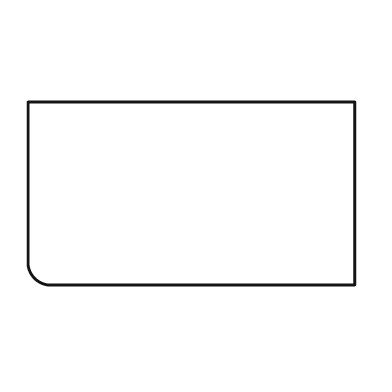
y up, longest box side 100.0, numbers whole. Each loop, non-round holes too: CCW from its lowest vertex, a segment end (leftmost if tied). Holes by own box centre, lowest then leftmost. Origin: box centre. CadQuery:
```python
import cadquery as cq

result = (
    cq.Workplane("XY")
    .moveTo(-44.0, -28.0)
    .lineTo(50.0, -28.0)
    .lineTo(50.0, 28.0)
    .lineTo(-50.0, 28.0)
    .lineTo(-50.0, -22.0)
    .threePointArc((-48.0, -26.0), (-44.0, -28.0))
    .close()
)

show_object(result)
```